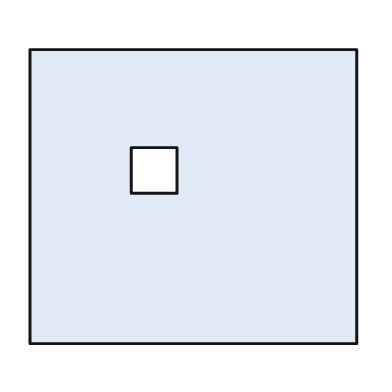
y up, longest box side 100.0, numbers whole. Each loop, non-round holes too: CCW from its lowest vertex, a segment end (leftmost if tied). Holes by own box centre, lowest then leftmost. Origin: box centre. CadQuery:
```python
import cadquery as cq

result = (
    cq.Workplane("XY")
    .moveTo(-50.0, -45.0)
    .lineTo(50.0, -45.0)
    .lineTo(50.0, 45.0)
    .lineTo(-50.0, 45.0)
    .close()
    .moveTo(-19.0, 1.0)
    .lineTo(-5.0, 1.0)
    .lineTo(-5.0, 15.0)
    .lineTo(-19.0, 15.0)
    .close()
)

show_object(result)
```